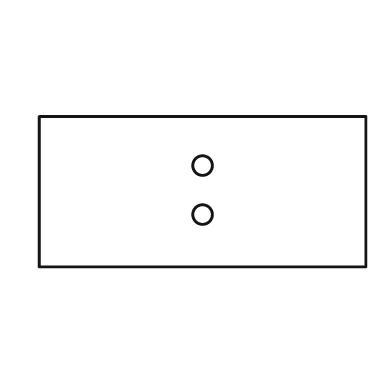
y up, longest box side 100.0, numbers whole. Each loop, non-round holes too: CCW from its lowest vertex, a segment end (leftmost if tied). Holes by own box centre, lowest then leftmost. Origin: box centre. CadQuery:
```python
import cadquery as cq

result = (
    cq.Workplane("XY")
    .moveTo(-50.0, -23.0)
    .lineTo(50.0, -23.0)
    .lineTo(50.0, 23.0)
    .lineTo(-50.0, 23.0)
    .close()
    .moveTo(0.0, -7.0)
    .circle(3.0)
    .moveTo(0.0, 8.0)
    .circle(3.0)
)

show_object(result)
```